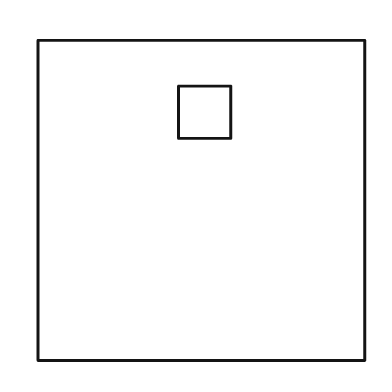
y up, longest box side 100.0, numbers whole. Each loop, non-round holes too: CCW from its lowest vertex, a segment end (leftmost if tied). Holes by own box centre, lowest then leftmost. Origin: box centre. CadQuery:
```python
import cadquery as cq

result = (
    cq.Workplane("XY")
    .moveTo(-50.0, -49.0)
    .lineTo(50.0, -49.0)
    .lineTo(50.0, 49.0)
    .lineTo(-50.0, 49.0)
    .close()
    .moveTo(-7.0, 19.0)
    .lineTo(9.0, 19.0)
    .lineTo(9.0, 35.0)
    .lineTo(-7.0, 35.0)
    .close()
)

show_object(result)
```